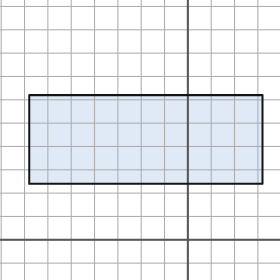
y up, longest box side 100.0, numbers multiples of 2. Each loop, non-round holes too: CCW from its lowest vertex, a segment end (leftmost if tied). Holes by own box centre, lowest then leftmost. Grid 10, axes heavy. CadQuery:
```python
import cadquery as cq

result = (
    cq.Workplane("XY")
    .moveTo(-68.0, 24.0)
    .lineTo(32.0, 24.0)
    .lineTo(32.0, 62.0)
    .lineTo(-68.0, 62.0)
    .close()
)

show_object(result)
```